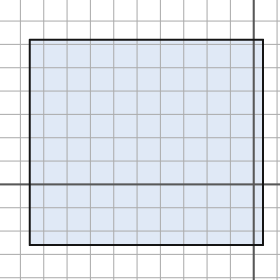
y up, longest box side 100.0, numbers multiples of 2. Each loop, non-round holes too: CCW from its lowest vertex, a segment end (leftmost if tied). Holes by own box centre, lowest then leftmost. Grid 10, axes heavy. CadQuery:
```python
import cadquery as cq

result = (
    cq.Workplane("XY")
    .moveTo(-96.0, -26.0)
    .lineTo(4.0, -26.0)
    .lineTo(4.0, 62.0)
    .lineTo(-96.0, 62.0)
    .close()
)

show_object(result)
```